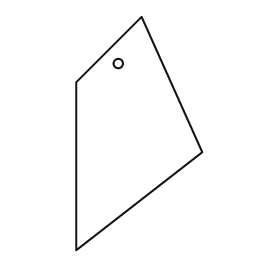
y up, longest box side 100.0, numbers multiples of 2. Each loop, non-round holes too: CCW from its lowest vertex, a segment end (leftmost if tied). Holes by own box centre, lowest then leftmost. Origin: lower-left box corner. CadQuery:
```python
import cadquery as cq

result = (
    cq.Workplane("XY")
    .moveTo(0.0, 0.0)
    .lineTo(54.0, 42.0)
    .lineTo(28.0, 100.0)
    .lineTo(0.0, 72.0)
    .close()
    .moveTo(18.0, 80.0)
    .circle(2.0)
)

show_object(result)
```